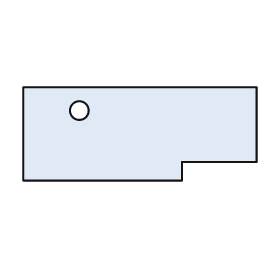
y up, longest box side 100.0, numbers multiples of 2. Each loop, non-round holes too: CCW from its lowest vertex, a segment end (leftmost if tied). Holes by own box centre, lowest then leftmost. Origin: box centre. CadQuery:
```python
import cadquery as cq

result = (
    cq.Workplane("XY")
    .moveTo(-50.0, -20.0)
    .lineTo(18.0, -20.0)
    .lineTo(18.0, -12.0)
    .lineTo(50.0, -12.0)
    .lineTo(50.0, 20.0)
    .lineTo(-50.0, 20.0)
    .close()
    .moveTo(-26.0, 10.0)
    .circle(4.0)
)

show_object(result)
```